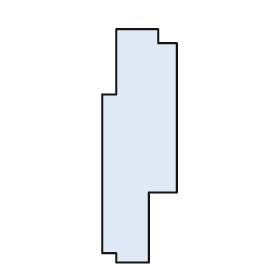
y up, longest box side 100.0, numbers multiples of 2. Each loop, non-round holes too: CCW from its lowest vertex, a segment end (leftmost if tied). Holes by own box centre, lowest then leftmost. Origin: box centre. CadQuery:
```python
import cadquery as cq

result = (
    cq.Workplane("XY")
    .moveTo(-10.0, -50.0)
    .lineTo(4.0, -50.0)
    .lineTo(4.0, -20.0)
    .lineTo(16.0, -20.0)
    .lineTo(16.0, 44.0)
    .lineTo(8.0, 44.0)
    .lineTo(8.0, 50.0)
    .lineTo(-10.0, 50.0)
    .lineTo(-10.0, 22.0)
    .lineTo(-16.0, 22.0)
    .lineTo(-16.0, -46.0)
    .lineTo(-10.0, -46.0)
    .close()
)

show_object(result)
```